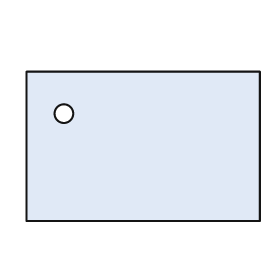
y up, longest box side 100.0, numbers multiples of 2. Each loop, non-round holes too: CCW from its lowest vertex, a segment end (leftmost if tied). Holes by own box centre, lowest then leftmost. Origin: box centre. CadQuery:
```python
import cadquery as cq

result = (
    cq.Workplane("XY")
    .moveTo(-50.0, -32.0)
    .lineTo(50.0, -32.0)
    .lineTo(50.0, 32.0)
    .lineTo(-50.0, 32.0)
    .close()
    .moveTo(-34.0, 14.0)
    .circle(4.0)
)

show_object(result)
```